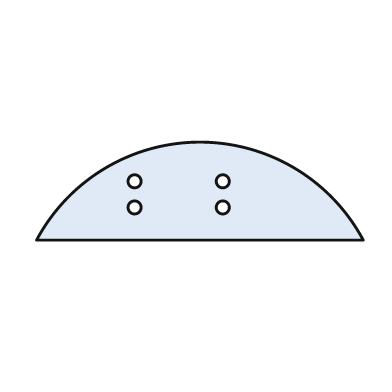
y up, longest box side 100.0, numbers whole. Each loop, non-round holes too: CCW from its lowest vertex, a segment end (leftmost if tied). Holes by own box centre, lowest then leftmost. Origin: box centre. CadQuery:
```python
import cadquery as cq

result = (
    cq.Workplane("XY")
    .moveTo(-50.0, -15.0)
    .lineTo(50.0, -15.0)
    .threePointArc((0.0, 15.0), (-50.0, -15.0))
    .close()
    .moveTo(-20.0, -5.0)
    .circle(2.0)
    .moveTo(7.0, -5.0)
    .circle(2.0)
    .moveTo(-20.0, 3.0)
    .circle(2.0)
    .moveTo(7.0, 3.0)
    .circle(2.0)
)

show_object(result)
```